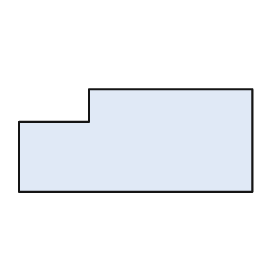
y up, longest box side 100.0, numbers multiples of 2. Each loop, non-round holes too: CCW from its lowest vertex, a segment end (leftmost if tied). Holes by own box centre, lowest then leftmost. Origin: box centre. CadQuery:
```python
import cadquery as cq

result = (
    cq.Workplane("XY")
    .moveTo(-50.0, -22.0)
    .lineTo(50.0, -22.0)
    .lineTo(50.0, 22.0)
    .lineTo(-20.0, 22.0)
    .lineTo(-20.0, 8.0)
    .lineTo(-50.0, 8.0)
    .close()
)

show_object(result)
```